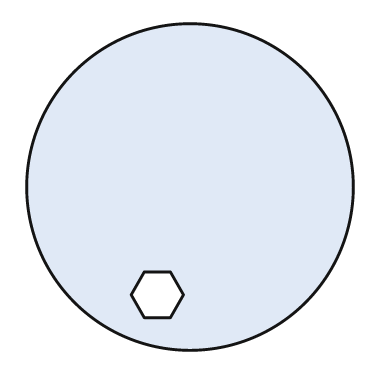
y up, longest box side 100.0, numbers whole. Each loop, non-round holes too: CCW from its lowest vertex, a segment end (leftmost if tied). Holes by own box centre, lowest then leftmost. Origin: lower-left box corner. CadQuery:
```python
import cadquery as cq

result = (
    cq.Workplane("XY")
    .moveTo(50.0, 50.0)
    .circle(50.0)
    .moveTo(36.0, 10.0)
    .lineTo(44.0, 10.0)
    .lineTo(48.0, 17.0)
    .lineTo(44.0, 24.0)
    .lineTo(36.0, 24.0)
    .lineTo(32.0, 17.0)
    .close()
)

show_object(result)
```